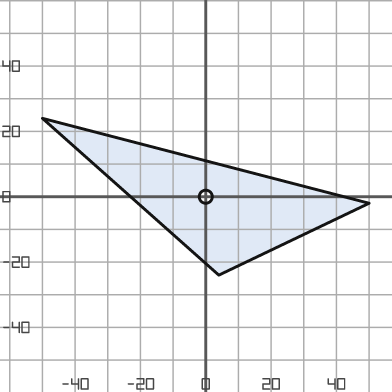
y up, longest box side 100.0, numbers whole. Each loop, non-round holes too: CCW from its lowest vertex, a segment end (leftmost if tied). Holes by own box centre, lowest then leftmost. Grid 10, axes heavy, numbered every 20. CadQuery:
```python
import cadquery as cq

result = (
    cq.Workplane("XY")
    .moveTo(4.0, -24.0)
    .lineTo(50.0, -2.0)
    .lineTo(-50.0, 24.0)
    .close()
    .moveTo(0.0, 0.0)
    .circle(2.0)
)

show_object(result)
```